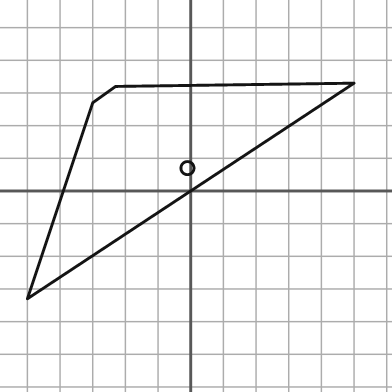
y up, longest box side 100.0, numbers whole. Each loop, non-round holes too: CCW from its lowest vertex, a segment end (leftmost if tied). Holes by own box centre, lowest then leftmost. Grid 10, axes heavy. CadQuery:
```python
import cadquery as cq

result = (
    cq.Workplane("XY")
    .moveTo(-50.0, -33.0)
    .lineTo(50.0, 33.0)
    .lineTo(-23.0, 32.0)
    .lineTo(-30.0, 27.0)
    .close()
    .moveTo(-1.0, 7.0)
    .circle(2.0)
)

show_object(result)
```